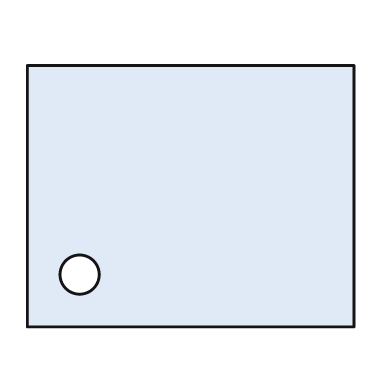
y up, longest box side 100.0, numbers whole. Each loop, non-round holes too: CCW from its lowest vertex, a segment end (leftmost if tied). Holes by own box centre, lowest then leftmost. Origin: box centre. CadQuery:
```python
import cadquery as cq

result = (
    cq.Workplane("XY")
    .moveTo(-50.0, -40.0)
    .lineTo(50.0, -40.0)
    .lineTo(50.0, 40.0)
    .lineTo(-50.0, 40.0)
    .close()
    .moveTo(-34.0, -24.0)
    .circle(6.0)
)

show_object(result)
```